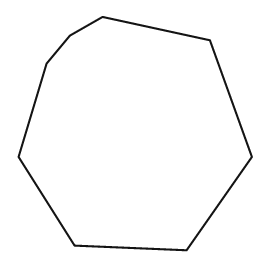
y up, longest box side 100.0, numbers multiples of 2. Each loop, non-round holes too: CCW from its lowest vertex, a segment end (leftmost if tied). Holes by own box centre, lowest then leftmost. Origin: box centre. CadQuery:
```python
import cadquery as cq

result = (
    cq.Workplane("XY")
    .moveTo(22.0, -50.0)
    .lineTo(50.0, -10.0)
    .lineTo(32.0, 40.0)
    .lineTo(-14.0, 50.0)
    .lineTo(-28.0, 42.0)
    .lineTo(-38.0, 30.0)
    .lineTo(-50.0, -10.0)
    .lineTo(-26.0, -48.0)
    .close()
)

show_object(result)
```